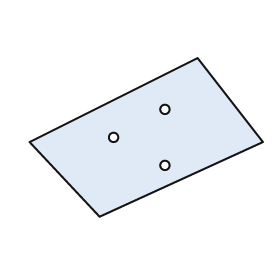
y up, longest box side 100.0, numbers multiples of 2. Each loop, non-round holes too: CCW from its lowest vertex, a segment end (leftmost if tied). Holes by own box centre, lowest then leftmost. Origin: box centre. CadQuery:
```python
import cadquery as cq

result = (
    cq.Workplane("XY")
    .moveTo(-20.0, -34.0)
    .lineTo(50.0, -2.0)
    .lineTo(22.0, 34.0)
    .lineTo(-50.0, -2.0)
    .close()
    .moveTo(8.0, -12.0)
    .circle(2.0)
    .moveTo(-14.0, 0.0)
    .circle(2.0)
    .moveTo(8.0, 12.0)
    .circle(2.0)
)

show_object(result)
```